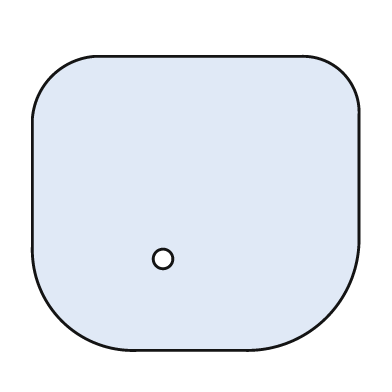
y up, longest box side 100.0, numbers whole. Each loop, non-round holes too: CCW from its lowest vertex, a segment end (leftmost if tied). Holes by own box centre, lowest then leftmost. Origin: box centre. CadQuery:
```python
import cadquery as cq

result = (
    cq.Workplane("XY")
    .moveTo(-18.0, -45.0)
    .lineTo(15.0, -45.0)
    .threePointArc((40.0, -35.0), (50.0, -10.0))
    .lineTo(50.0, 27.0)
    .threePointArc((45.0, 40.0), (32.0, 45.0))
    .lineTo(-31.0, 45.0)
    .threePointArc((-44.0, 39.0), (-50.0, 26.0))
    .lineTo(-50.0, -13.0)
    .threePointArc((-41.0, -36.0), (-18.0, -45.0))
    .close()
    .moveTo(-10.0, -17.0)
    .circle(3.0)
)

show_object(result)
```